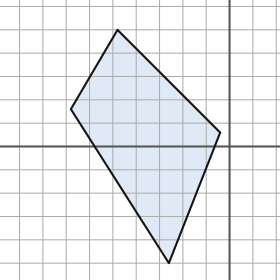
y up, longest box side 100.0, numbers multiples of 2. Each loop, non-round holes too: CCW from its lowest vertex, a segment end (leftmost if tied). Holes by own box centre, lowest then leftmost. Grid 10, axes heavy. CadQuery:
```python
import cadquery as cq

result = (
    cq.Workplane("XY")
    .moveTo(-26.0, -50.0)
    .lineTo(-4.0, 6.0)
    .lineTo(-48.0, 50.0)
    .lineTo(-68.0, 16.0)
    .close()
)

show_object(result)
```